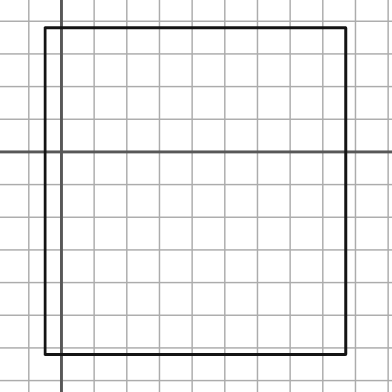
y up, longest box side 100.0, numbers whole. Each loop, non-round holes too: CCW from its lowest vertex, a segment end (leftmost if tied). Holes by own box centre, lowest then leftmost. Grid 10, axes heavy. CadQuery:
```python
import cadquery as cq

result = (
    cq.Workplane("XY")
    .moveTo(-5.0, -62.0)
    .lineTo(87.0, -62.0)
    .lineTo(87.0, 38.0)
    .lineTo(-5.0, 38.0)
    .close()
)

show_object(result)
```